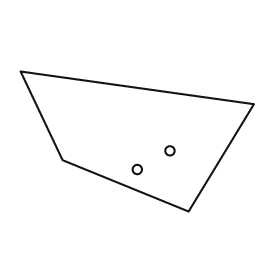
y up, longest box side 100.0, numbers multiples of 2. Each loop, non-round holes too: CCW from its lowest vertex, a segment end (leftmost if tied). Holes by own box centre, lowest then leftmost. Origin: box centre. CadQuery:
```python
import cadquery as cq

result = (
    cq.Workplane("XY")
    .moveTo(22.0, -30.0)
    .lineTo(50.0, 16.0)
    .lineTo(-50.0, 30.0)
    .lineTo(-32.0, -8.0)
    .close()
    .moveTo(0.0, -12.0)
    .circle(2.0)
    .moveTo(14.0, -4.0)
    .circle(2.0)
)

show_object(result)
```